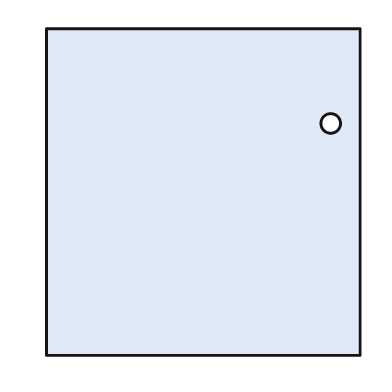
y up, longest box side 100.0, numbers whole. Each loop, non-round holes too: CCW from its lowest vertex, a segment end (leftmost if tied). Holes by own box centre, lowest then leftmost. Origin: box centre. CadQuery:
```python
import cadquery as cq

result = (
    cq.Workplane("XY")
    .moveTo(-48.0, -50.0)
    .lineTo(48.0, -50.0)
    .lineTo(48.0, 50.0)
    .lineTo(-48.0, 50.0)
    .close()
    .moveTo(39.0, 21.0)
    .circle(3.0)
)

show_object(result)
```